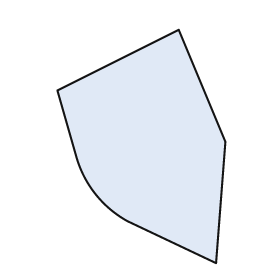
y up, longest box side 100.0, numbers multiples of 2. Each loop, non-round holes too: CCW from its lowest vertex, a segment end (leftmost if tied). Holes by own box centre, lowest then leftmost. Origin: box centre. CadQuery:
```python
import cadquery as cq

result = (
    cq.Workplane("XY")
    .moveTo(32.0, -50.0)
    .lineTo(36.0, 2.0)
    .lineTo(16.0, 50.0)
    .lineTo(-36.0, 24.0)
    .lineTo(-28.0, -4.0)
    .threePointArc((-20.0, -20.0), (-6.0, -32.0))
    .close()
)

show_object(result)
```